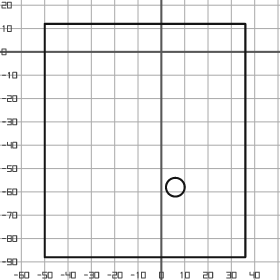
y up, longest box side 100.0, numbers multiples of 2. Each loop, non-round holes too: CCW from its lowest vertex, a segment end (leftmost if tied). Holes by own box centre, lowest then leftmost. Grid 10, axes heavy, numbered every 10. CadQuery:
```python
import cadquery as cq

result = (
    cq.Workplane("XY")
    .moveTo(-50.0, -88.0)
    .lineTo(36.0, -88.0)
    .lineTo(36.0, 12.0)
    .lineTo(-50.0, 12.0)
    .close()
    .moveTo(6.0, -58.0)
    .circle(4.0)
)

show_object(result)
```